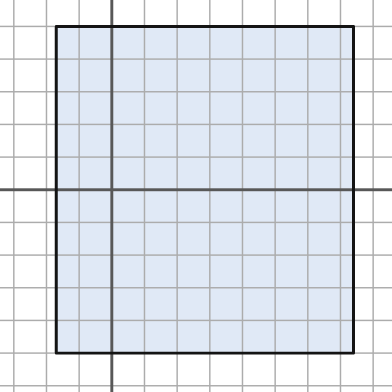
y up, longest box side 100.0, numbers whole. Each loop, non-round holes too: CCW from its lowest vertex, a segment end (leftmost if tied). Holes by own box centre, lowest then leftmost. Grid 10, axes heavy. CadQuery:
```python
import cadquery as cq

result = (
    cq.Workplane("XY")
    .moveTo(-17.0, -50.0)
    .lineTo(74.0, -50.0)
    .lineTo(74.0, 50.0)
    .lineTo(-17.0, 50.0)
    .close()
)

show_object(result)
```